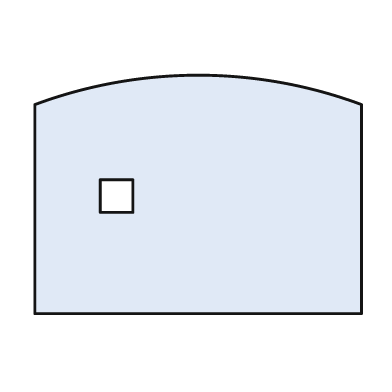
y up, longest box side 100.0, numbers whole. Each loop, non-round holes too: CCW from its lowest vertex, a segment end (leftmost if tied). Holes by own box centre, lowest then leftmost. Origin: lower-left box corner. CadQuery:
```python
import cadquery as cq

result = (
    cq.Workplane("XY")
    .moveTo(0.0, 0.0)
    .lineTo(100.0, 0.0)
    .lineTo(100.0, 64.0)
    .threePointArc((50.0, 73.0), (0.0, 64.0))
    .close()
    .moveTo(20.0, 31.0)
    .lineTo(30.0, 31.0)
    .lineTo(30.0, 41.0)
    .lineTo(20.0, 41.0)
    .close()
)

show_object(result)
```